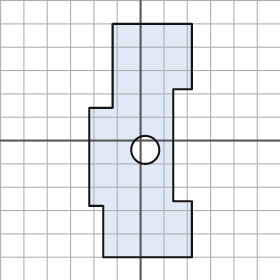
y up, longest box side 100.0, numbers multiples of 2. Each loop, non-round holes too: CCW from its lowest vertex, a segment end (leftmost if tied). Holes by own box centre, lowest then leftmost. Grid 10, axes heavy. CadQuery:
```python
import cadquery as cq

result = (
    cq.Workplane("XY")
    .moveTo(-16.0, -50.0)
    .lineTo(22.0, -50.0)
    .lineTo(22.0, -26.0)
    .lineTo(14.0, -26.0)
    .lineTo(14.0, 22.0)
    .lineTo(22.0, 22.0)
    .lineTo(22.0, 50.0)
    .lineTo(-12.0, 50.0)
    .lineTo(-12.0, 14.0)
    .lineTo(-22.0, 14.0)
    .lineTo(-22.0, -28.0)
    .lineTo(-16.0, -28.0)
    .close()
    .moveTo(2.0, -4.0)
    .circle(6.0)
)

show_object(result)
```